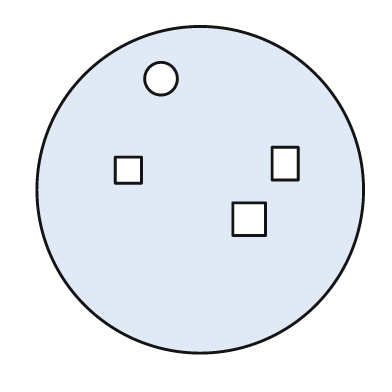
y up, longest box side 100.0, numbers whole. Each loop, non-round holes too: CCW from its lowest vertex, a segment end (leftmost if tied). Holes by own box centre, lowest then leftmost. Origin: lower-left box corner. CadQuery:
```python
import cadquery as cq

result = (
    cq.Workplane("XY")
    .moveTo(50.0, 50.0)
    .circle(50.0)
    .moveTo(60.0, 36.0)
    .lineTo(70.0, 36.0)
    .lineTo(70.0, 46.0)
    .lineTo(60.0, 46.0)
    .close()
    .moveTo(24.0, 52.0)
    .lineTo(32.0, 52.0)
    .lineTo(32.0, 60.0)
    .lineTo(24.0, 60.0)
    .close()
    .moveTo(72.0, 53.0)
    .lineTo(80.0, 53.0)
    .lineTo(80.0, 63.0)
    .lineTo(72.0, 63.0)
    .close()
    .moveTo(38.0, 84.0)
    .circle(5.0)
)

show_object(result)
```